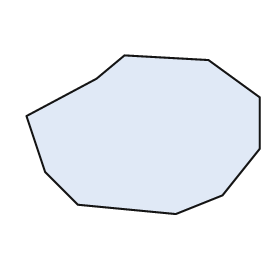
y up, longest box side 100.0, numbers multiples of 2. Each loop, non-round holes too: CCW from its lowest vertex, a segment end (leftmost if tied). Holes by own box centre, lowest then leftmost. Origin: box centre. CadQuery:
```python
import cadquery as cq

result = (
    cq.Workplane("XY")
    .moveTo(14.0, -34.0)
    .lineTo(34.0, -26.0)
    .lineTo(50.0, -6.0)
    .lineTo(50.0, 16.0)
    .lineTo(28.0, 32.0)
    .lineTo(-8.0, 34.0)
    .lineTo(-20.0, 24.0)
    .lineTo(-50.0, 8.0)
    .lineTo(-42.0, -16.0)
    .lineTo(-28.0, -30.0)
    .close()
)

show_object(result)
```